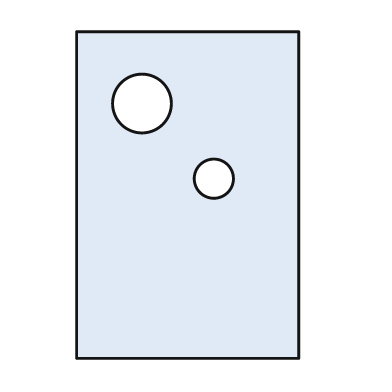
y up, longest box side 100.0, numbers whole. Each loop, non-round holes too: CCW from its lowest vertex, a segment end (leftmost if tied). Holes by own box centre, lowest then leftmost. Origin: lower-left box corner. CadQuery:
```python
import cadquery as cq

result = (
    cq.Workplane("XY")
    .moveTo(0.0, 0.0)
    .lineTo(68.0, 0.0)
    .lineTo(68.0, 100.0)
    .lineTo(0.0, 100.0)
    .close()
    .moveTo(42.0, 55.0)
    .circle(6.0)
    .moveTo(20.0, 78.0)
    .circle(9.0)
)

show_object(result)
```